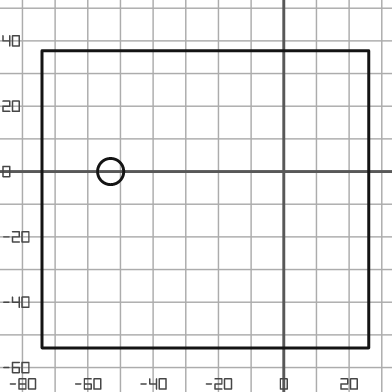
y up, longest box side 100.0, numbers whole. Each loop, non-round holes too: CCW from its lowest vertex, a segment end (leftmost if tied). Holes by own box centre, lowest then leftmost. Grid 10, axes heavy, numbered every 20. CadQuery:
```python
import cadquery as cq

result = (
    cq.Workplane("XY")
    .moveTo(-74.0, -54.0)
    .lineTo(26.0, -54.0)
    .lineTo(26.0, 37.0)
    .lineTo(-74.0, 37.0)
    .close()
    .moveTo(-53.0, 0.0)
    .circle(4.0)
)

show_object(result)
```